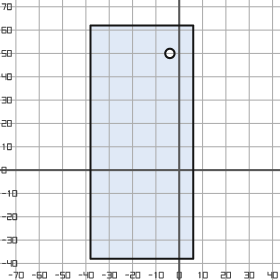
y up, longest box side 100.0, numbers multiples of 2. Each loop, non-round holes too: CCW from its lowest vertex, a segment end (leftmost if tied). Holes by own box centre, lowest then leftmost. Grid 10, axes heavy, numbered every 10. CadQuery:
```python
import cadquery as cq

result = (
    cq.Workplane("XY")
    .moveTo(-38.0, -38.0)
    .lineTo(6.0, -38.0)
    .lineTo(6.0, 62.0)
    .lineTo(-38.0, 62.0)
    .close()
    .moveTo(-4.0, 50.0)
    .circle(2.0)
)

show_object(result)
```